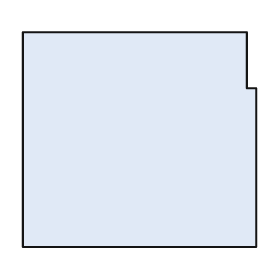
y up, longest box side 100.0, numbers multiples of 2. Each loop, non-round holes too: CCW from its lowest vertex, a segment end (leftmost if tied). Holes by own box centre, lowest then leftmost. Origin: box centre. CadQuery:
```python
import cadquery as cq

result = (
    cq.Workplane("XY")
    .moveTo(-50.0, -46.0)
    .lineTo(50.0, -46.0)
    .lineTo(50.0, 22.0)
    .lineTo(46.0, 22.0)
    .lineTo(46.0, 46.0)
    .lineTo(-50.0, 46.0)
    .close()
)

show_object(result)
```